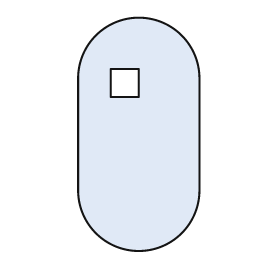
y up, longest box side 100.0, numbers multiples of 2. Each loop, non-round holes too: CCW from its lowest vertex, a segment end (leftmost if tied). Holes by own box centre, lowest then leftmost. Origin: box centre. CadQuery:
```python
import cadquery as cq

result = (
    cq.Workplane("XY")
    .moveTo(-26.0, -24.0)
    .threePointArc((0.0, -50.0), (26.0, -24.0))
    .lineTo(26.0, 24.0)
    .threePointArc((0.0, 50.0), (-26.0, 24.0))
    .close()
    .moveTo(-12.0, 16.0)
    .lineTo(0.0, 16.0)
    .lineTo(0.0, 28.0)
    .lineTo(-12.0, 28.0)
    .close()
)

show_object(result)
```